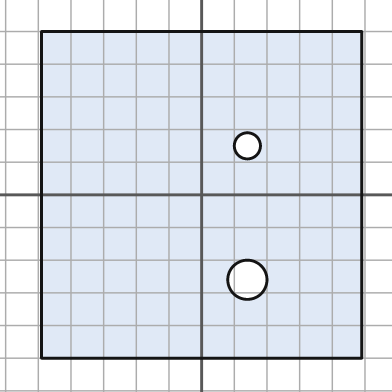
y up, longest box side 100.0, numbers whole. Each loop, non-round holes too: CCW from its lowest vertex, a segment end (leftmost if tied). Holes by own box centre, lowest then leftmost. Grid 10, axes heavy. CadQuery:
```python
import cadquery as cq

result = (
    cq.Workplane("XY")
    .moveTo(-49.0, -50.0)
    .lineTo(49.0, -50.0)
    .lineTo(49.0, 50.0)
    .lineTo(-49.0, 50.0)
    .close()
    .moveTo(14.0, -26.0)
    .circle(6.0)
    .moveTo(14.0, 15.0)
    .circle(4.0)
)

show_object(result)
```